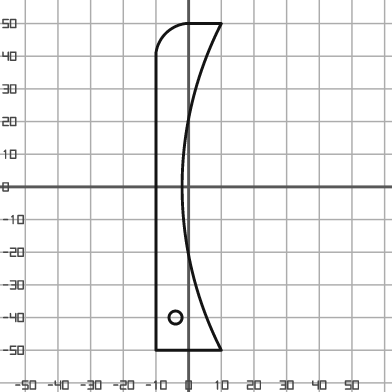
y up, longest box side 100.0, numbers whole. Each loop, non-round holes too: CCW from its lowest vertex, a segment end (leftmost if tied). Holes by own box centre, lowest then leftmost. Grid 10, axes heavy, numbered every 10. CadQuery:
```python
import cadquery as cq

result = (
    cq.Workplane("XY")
    .moveTo(-10.0, -50.0)
    .lineTo(10.0, -50.0)
    .threePointArc((-2.0, 0.0), (10.0, 50.0))
    .lineTo(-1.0, 50.0)
    .threePointArc((-7.0, 47.0), (-10.0, 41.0))
    .close()
    .moveTo(-4.0, -40.0)
    .circle(2.0)
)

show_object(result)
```